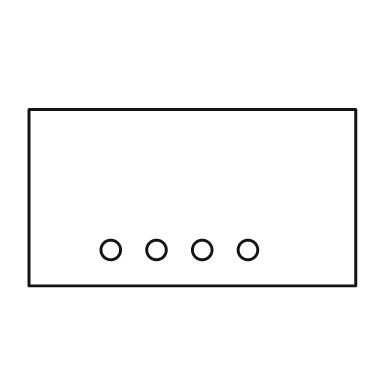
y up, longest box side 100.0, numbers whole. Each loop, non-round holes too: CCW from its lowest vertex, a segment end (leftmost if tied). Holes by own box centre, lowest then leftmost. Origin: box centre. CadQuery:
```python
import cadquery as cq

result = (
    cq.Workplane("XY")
    .moveTo(-50.0, -27.0)
    .lineTo(50.0, -27.0)
    .lineTo(50.0, 27.0)
    .lineTo(-50.0, 27.0)
    .close()
    .moveTo(-25.0, -16.0)
    .circle(3.0)
    .moveTo(-11.0, -16.0)
    .circle(3.0)
    .moveTo(3.0, -16.0)
    .circle(3.0)
    .moveTo(17.0, -16.0)
    .circle(3.0)
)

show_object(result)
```